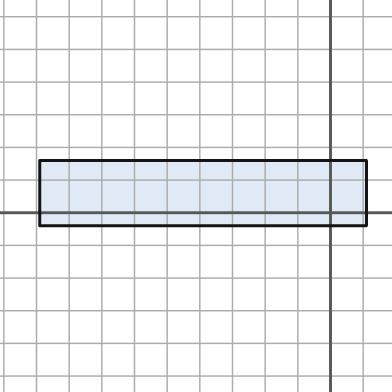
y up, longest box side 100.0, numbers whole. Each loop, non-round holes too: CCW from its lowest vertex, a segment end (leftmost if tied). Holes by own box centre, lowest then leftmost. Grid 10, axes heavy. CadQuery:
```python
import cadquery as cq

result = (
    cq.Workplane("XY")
    .moveTo(-89.0, -4.0)
    .lineTo(11.0, -4.0)
    .lineTo(11.0, 16.0)
    .lineTo(-89.0, 16.0)
    .close()
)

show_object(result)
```